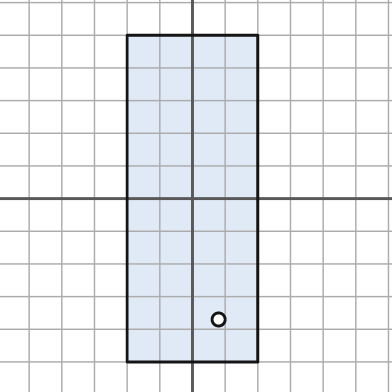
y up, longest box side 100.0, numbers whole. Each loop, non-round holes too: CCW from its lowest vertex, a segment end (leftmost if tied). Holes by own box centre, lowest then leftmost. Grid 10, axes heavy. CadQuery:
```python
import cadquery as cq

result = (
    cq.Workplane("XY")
    .moveTo(-20.0, -50.0)
    .lineTo(20.0, -50.0)
    .lineTo(20.0, 50.0)
    .lineTo(-20.0, 50.0)
    .close()
    .moveTo(8.0, -37.0)
    .circle(2.0)
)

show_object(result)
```